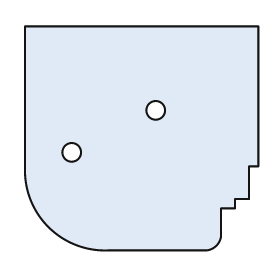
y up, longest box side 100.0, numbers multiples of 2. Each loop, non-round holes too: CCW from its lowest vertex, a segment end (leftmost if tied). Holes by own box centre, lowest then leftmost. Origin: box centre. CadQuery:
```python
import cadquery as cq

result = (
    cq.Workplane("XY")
    .moveTo(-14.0, -48.0)
    .lineTo(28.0, -48.0)
    .threePointArc((32.0, -46.0), (34.0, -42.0))
    .lineTo(34.0, -30.0)
    .lineTo(40.0, -30.0)
    .lineTo(40.0, -26.0)
    .lineTo(46.0, -26.0)
    .lineTo(46.0, -12.0)
    .lineTo(50.0, -12.0)
    .lineTo(50.0, 48.0)
    .lineTo(-50.0, 48.0)
    .lineTo(-50.0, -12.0)
    .threePointArc((-40.0, -38.0), (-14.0, -48.0))
    .close()
    .moveTo(-30.0, -6.0)
    .circle(4.0)
    .moveTo(6.0, 12.0)
    .circle(4.0)
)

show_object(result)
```